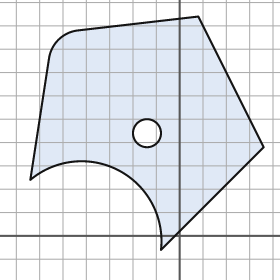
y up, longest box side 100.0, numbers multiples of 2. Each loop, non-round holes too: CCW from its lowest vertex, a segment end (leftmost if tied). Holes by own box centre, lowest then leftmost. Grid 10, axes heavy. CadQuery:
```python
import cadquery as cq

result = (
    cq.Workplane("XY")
    .moveTo(-8.0, -6.0)
    .lineTo(36.0, 38.0)
    .lineTo(8.0, 94.0)
    .lineTo(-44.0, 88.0)
    .threePointArc((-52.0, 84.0), (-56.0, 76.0))
    .lineTo(-64.0, 24.0)
    .threePointArc((-26.0, 28.0), (-8.0, -6.0))
    .close()
    .moveTo(-14.0, 44.0)
    .circle(6.0)
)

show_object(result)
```